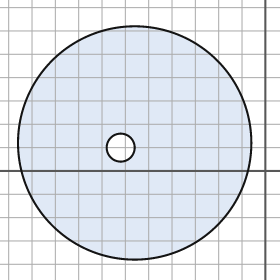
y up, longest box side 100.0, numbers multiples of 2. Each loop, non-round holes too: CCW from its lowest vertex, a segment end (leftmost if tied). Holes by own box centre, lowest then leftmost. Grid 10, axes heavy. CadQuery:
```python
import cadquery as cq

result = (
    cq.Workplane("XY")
    .moveTo(-56.0, 12.0)
    .circle(50.0)
    .moveTo(-62.0, 10.0)
    .circle(6.0)
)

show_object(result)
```